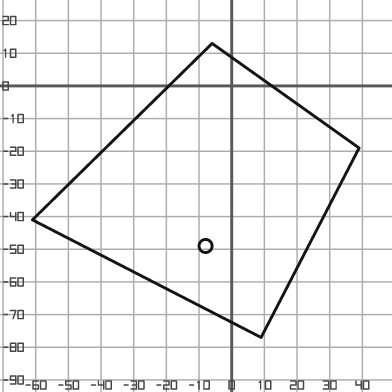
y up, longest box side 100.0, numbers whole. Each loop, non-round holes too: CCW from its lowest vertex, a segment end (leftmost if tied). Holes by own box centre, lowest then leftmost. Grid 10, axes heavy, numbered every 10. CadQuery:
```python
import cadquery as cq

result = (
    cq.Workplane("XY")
    .moveTo(9.0, -77.0)
    .lineTo(39.0, -19.0)
    .lineTo(-6.0, 13.0)
    .lineTo(-61.0, -41.0)
    .close()
    .moveTo(-8.0, -49.0)
    .circle(2.0)
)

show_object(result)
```